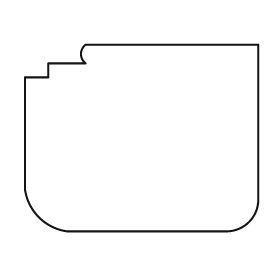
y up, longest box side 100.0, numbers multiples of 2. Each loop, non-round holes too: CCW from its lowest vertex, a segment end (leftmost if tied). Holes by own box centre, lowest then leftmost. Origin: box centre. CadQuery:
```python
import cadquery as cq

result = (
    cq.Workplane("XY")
    .moveTo(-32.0, -40.0)
    .lineTo(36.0, -40.0)
    .threePointArc((46.0, -36.0), (50.0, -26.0))
    .lineTo(50.0, 40.0)
    .lineTo(-24.0, 40.0)
    .threePointArc((-26.0, 36.0), (-24.0, 32.0))
    .lineTo(-40.0, 32.0)
    .lineTo(-40.0, 26.0)
    .lineTo(-50.0, 26.0)
    .lineTo(-50.0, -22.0)
    .threePointArc((-44.0, -34.0), (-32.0, -40.0))
    .close()
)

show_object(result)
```